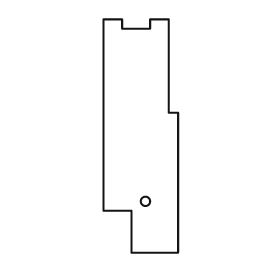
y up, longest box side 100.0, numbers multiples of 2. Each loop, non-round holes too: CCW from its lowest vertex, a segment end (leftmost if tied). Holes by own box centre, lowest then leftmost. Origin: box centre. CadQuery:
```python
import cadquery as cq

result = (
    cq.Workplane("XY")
    .moveTo(-4.0, -50.0)
    .lineTo(16.0, -50.0)
    .lineTo(16.0, 10.0)
    .lineTo(12.0, 10.0)
    .lineTo(12.0, 50.0)
    .lineTo(4.0, 50.0)
    .lineTo(4.0, 46.0)
    .lineTo(-8.0, 46.0)
    .lineTo(-8.0, 50.0)
    .lineTo(-16.0, 50.0)
    .lineTo(-16.0, -32.0)
    .lineTo(-4.0, -32.0)
    .close()
    .moveTo(2.0, -28.0)
    .circle(2.0)
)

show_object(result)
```